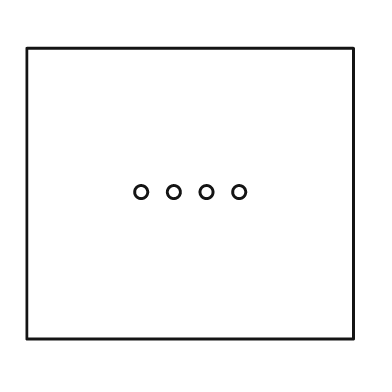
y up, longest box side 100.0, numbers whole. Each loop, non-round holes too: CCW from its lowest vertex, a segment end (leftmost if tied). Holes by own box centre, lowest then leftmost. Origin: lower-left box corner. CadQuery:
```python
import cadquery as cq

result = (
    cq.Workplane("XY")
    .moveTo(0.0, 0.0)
    .lineTo(100.0, 0.0)
    .lineTo(100.0, 89.0)
    .lineTo(0.0, 89.0)
    .close()
    .moveTo(35.0, 45.0)
    .circle(2.0)
    .moveTo(45.0, 45.0)
    .circle(2.0)
    .moveTo(55.0, 45.0)
    .circle(2.0)
    .moveTo(65.0, 45.0)
    .circle(2.0)
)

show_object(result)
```